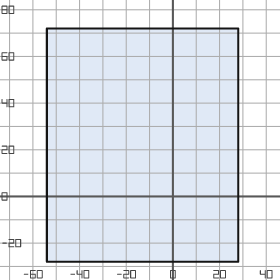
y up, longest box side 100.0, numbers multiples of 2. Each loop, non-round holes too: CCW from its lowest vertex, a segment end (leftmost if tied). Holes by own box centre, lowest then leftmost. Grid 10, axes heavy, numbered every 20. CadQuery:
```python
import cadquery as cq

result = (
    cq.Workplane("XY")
    .moveTo(-54.0, -28.0)
    .lineTo(28.0, -28.0)
    .lineTo(28.0, 72.0)
    .lineTo(-54.0, 72.0)
    .close()
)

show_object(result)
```